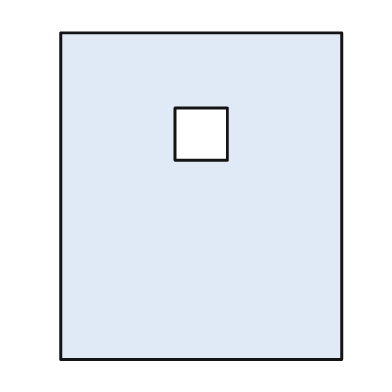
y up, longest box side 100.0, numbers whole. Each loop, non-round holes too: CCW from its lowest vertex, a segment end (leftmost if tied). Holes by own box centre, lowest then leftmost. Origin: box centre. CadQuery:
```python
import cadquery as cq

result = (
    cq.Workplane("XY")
    .moveTo(-43.0, -50.0)
    .lineTo(43.0, -50.0)
    .lineTo(43.0, 50.0)
    .lineTo(-43.0, 50.0)
    .close()
    .moveTo(-8.0, 11.0)
    .lineTo(8.0, 11.0)
    .lineTo(8.0, 27.0)
    .lineTo(-8.0, 27.0)
    .close()
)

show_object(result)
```